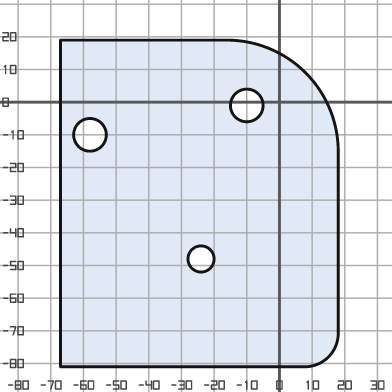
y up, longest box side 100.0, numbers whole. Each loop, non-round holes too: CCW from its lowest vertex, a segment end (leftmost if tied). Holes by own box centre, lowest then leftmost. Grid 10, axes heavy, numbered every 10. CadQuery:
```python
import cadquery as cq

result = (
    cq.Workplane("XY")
    .moveTo(-67.0, -81.0)
    .lineTo(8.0, -81.0)
    .threePointArc((15.0, -78.0), (18.0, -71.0))
    .lineTo(18.0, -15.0)
    .threePointArc((8.0, 9.0), (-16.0, 19.0))
    .lineTo(-67.0, 19.0)
    .close()
    .moveTo(-24.0, -48.0)
    .circle(4.0)
    .moveTo(-58.0, -10.0)
    .circle(5.0)
    .moveTo(-10.0, -1.0)
    .circle(5.0)
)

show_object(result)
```